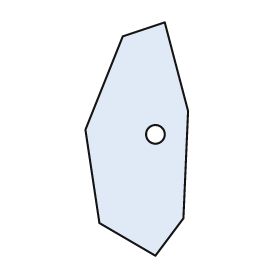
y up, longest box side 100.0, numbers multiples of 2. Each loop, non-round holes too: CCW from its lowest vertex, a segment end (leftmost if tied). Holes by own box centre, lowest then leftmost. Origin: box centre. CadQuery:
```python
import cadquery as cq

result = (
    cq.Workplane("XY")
    .moveTo(8.0, -50.0)
    .lineTo(20.0, -34.0)
    .lineTo(22.0, 12.0)
    .lineTo(12.0, 50.0)
    .lineTo(-6.0, 44.0)
    .lineTo(-22.0, 4.0)
    .lineTo(-16.0, -36.0)
    .close()
    .moveTo(8.0, 2.0)
    .circle(4.0)
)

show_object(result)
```